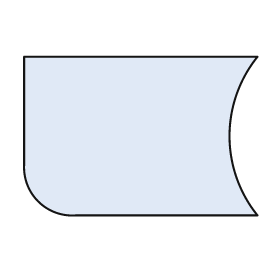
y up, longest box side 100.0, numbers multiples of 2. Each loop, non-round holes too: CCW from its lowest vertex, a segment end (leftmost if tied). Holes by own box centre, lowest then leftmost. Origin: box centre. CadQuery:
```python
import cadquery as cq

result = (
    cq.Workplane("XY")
    .moveTo(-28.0, -34.0)
    .lineTo(50.0, -34.0)
    .threePointArc((38.0, 0.0), (50.0, 34.0))
    .lineTo(-50.0, 34.0)
    .lineTo(-50.0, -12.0)
    .threePointArc((-44.0, -28.0), (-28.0, -34.0))
    .close()
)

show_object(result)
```